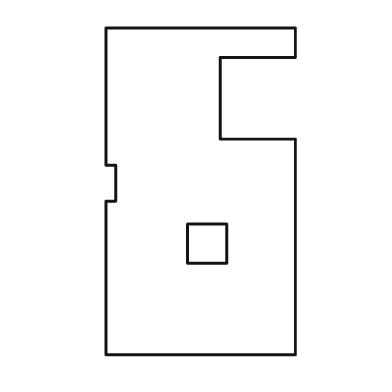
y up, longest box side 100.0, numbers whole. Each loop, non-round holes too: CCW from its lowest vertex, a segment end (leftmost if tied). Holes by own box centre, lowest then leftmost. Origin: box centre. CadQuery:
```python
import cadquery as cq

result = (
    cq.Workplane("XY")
    .moveTo(-29.0, -50.0)
    .lineTo(29.0, -50.0)
    .lineTo(29.0, 16.0)
    .lineTo(6.0, 16.0)
    .lineTo(6.0, 41.0)
    .lineTo(29.0, 41.0)
    .lineTo(29.0, 50.0)
    .lineTo(-29.0, 50.0)
    .lineTo(-29.0, 8.0)
    .lineTo(-26.0, 8.0)
    .lineTo(-26.0, -3.0)
    .lineTo(-29.0, -3.0)
    .close()
    .moveTo(-4.0, -22.0)
    .lineTo(8.0, -22.0)
    .lineTo(8.0, -10.0)
    .lineTo(-4.0, -10.0)
    .close()
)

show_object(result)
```